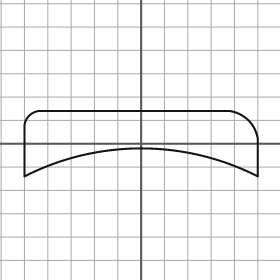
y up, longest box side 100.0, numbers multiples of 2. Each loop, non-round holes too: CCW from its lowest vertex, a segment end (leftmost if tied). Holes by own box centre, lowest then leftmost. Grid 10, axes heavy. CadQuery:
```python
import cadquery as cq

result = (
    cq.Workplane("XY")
    .moveTo(-50.0, -14.0)
    .threePointArc((0.0, -2.0), (50.0, -14.0))
    .lineTo(50.0, 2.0)
    .threePointArc((46.0, 10.0), (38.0, 14.0))
    .lineTo(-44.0, 14.0)
    .threePointArc((-48.0, 12.0), (-50.0, 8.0))
    .close()
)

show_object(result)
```